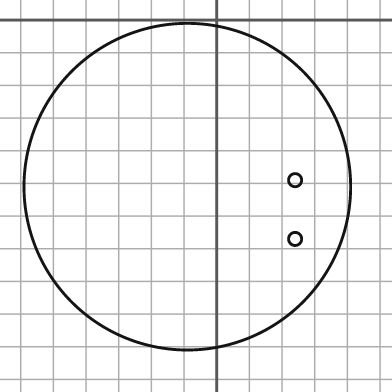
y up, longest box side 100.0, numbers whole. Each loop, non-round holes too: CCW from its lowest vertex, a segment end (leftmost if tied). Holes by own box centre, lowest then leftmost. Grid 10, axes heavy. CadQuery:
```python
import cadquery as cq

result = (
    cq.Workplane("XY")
    .moveTo(-9.0, -51.0)
    .circle(50.0)
    .moveTo(24.0, -67.0)
    .circle(2.0)
    .moveTo(24.0, -49.0)
    .circle(2.0)
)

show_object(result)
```